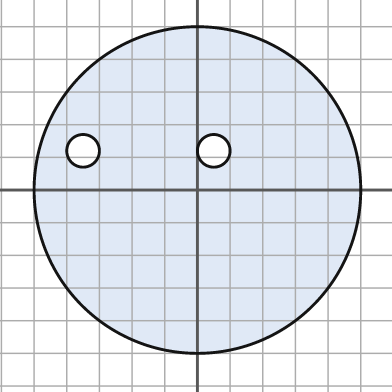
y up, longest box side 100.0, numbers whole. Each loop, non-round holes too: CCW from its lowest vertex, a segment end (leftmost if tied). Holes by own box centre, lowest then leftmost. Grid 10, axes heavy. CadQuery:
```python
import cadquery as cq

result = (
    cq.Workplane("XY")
    .moveTo(0.0, 0.0)
    .circle(50.0)
    .moveTo(-35.0, 12.0)
    .circle(5.0)
    .moveTo(5.0, 12.0)
    .circle(5.0)
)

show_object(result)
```